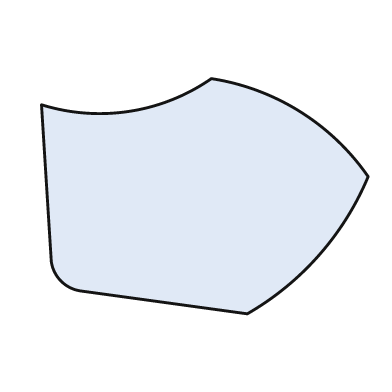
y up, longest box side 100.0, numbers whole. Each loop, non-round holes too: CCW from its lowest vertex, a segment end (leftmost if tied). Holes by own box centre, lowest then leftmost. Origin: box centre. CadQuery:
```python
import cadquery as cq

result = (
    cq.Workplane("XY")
    .moveTo(13.0, -36.0)
    .threePointArc((35.0, -18.0), (50.0, 6.0))
    .threePointArc((29.0, 26.0), (2.0, 36.0))
    .threePointArc((-23.0, 26.0), (-50.0, 28.0))
    .lineTo(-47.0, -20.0)
    .threePointArc((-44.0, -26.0), (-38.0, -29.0))
    .close()
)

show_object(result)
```